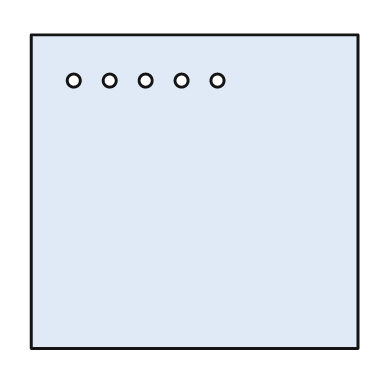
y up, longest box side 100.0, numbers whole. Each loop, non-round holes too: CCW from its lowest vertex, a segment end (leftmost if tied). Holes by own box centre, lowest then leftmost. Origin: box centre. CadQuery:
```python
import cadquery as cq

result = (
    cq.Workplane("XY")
    .moveTo(-50.0, -48.0)
    .lineTo(50.0, -48.0)
    .lineTo(50.0, 48.0)
    .lineTo(-50.0, 48.0)
    .close()
    .moveTo(-37.0, 34.0)
    .circle(2.0)
    .moveTo(-26.0, 34.0)
    .circle(2.0)
    .moveTo(-15.0, 34.0)
    .circle(2.0)
    .moveTo(-4.0, 34.0)
    .circle(2.0)
    .moveTo(7.0, 34.0)
    .circle(2.0)
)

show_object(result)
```